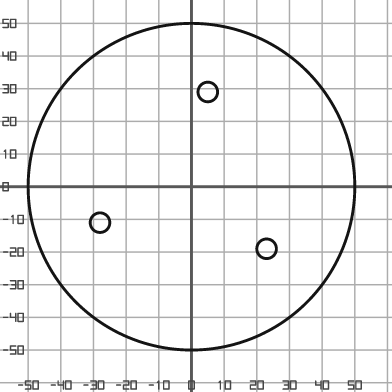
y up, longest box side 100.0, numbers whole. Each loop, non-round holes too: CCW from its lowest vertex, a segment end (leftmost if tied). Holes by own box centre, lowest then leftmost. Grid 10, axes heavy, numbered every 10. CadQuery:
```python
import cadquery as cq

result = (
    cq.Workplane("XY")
    .moveTo(0.0, 0.0)
    .circle(50.0)
    .moveTo(23.0, -19.0)
    .circle(3.0)
    .moveTo(-28.0, -11.0)
    .circle(3.0)
    .moveTo(5.0, 29.0)
    .circle(3.0)
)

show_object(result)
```